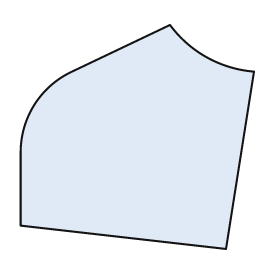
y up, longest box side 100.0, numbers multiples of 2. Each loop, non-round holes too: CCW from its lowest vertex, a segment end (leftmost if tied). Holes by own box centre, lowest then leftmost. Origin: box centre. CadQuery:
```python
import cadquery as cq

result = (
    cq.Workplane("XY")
    .moveTo(38.0, -48.0)
    .lineTo(50.0, 28.0)
    .threePointArc((30.0, 34.0), (14.0, 48.0))
    .lineTo(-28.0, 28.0)
    .threePointArc((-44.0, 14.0), (-50.0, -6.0))
    .lineTo(-50.0, -38.0)
    .close()
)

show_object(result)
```